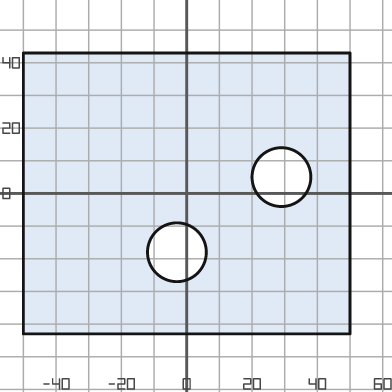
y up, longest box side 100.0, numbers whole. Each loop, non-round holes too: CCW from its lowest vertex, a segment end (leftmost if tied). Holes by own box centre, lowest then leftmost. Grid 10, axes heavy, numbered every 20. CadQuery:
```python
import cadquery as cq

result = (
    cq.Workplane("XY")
    .moveTo(-50.0, -43.0)
    .lineTo(50.0, -43.0)
    .lineTo(50.0, 43.0)
    .lineTo(-50.0, 43.0)
    .close()
    .moveTo(-3.0, -18.0)
    .circle(9.0)
    .moveTo(29.0, 5.0)
    .circle(9.0)
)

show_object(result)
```